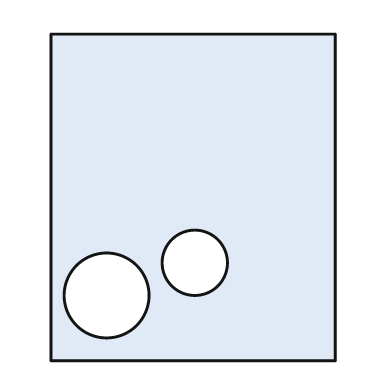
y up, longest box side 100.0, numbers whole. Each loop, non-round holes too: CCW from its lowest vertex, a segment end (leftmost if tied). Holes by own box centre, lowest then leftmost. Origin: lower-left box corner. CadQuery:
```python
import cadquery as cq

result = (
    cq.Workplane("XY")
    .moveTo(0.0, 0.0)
    .lineTo(87.0, 0.0)
    .lineTo(87.0, 100.0)
    .lineTo(0.0, 100.0)
    .close()
    .moveTo(17.0, 20.0)
    .circle(13.0)
    .moveTo(44.0, 30.0)
    .circle(10.0)
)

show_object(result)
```